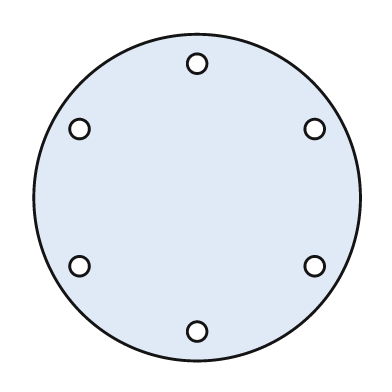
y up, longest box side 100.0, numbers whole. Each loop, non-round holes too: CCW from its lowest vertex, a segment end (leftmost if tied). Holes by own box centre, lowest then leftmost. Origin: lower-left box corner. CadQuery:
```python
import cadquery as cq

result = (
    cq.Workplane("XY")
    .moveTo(50.0, 50.0)
    .circle(50.0)
    .moveTo(50.0, 9.0)
    .circle(3.0)
    .moveTo(14.0, 29.0)
    .circle(3.0)
    .moveTo(86.0, 29.0)
    .circle(3.0)
    .moveTo(14.0, 71.0)
    .circle(3.0)
    .moveTo(86.0, 71.0)
    .circle(3.0)
    .moveTo(50.0, 91.0)
    .circle(3.0)
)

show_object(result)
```